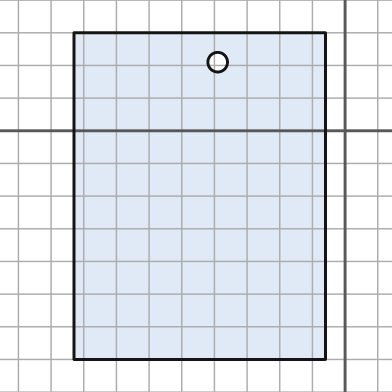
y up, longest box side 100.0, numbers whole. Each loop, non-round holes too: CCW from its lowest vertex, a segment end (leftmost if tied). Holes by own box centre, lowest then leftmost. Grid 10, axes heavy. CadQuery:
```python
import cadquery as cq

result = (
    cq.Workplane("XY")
    .moveTo(-83.0, -70.0)
    .lineTo(-6.0, -70.0)
    .lineTo(-6.0, 30.0)
    .lineTo(-83.0, 30.0)
    .close()
    .moveTo(-39.0, 21.0)
    .circle(3.0)
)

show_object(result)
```